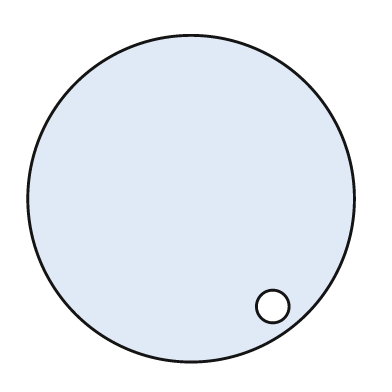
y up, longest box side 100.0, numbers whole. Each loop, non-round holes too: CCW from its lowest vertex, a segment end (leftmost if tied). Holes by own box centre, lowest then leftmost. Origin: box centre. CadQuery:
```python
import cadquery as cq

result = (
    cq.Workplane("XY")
    .moveTo(0.0, 0.0)
    .circle(50.0)
    .moveTo(25.0, -33.0)
    .circle(5.0)
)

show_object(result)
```